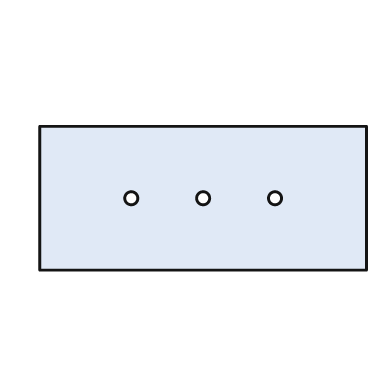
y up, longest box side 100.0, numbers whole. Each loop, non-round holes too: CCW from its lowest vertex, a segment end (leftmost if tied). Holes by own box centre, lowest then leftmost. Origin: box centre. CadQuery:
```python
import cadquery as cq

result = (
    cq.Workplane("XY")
    .moveTo(-50.0, -22.0)
    .lineTo(50.0, -22.0)
    .lineTo(50.0, 22.0)
    .lineTo(-50.0, 22.0)
    .close()
    .moveTo(-22.0, 0.0)
    .circle(2.0)
    .moveTo(0.0, 0.0)
    .circle(2.0)
    .moveTo(22.0, 0.0)
    .circle(2.0)
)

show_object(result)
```